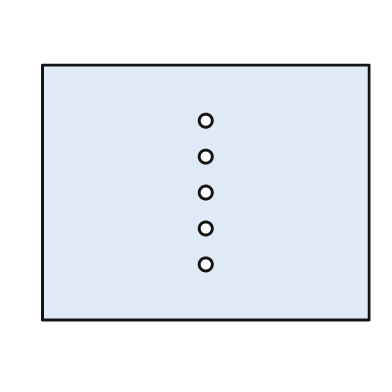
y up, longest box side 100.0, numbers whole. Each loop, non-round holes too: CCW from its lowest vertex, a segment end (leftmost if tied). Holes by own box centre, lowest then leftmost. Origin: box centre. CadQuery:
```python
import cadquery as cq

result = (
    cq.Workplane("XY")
    .moveTo(-50.0, -39.0)
    .lineTo(50.0, -39.0)
    .lineTo(50.0, 39.0)
    .lineTo(-50.0, 39.0)
    .close()
    .moveTo(0.0, -22.0)
    .circle(2.0)
    .moveTo(0.0, -11.0)
    .circle(2.0)
    .moveTo(0.0, 0.0)
    .circle(2.0)
    .moveTo(0.0, 11.0)
    .circle(2.0)
    .moveTo(0.0, 22.0)
    .circle(2.0)
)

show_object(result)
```